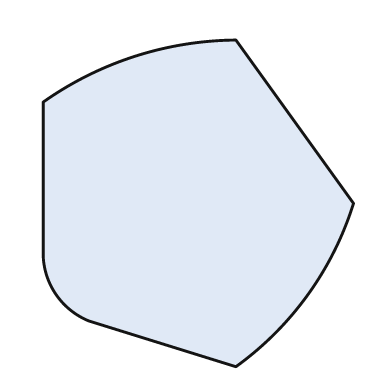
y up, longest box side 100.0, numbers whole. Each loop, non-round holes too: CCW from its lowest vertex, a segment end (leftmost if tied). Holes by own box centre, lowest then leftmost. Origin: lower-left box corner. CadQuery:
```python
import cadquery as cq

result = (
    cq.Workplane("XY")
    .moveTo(59.0, 0.0)
    .threePointArc((81.0, 22.0), (95.0, 50.0))
    .lineTo(59.0, 100.0)
    .threePointArc((28.0, 95.0), (0.0, 81.0))
    .lineTo(0.0, 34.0)
    .threePointArc((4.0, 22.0), (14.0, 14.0))
    .close()
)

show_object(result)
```